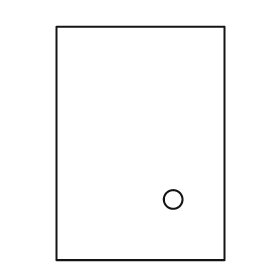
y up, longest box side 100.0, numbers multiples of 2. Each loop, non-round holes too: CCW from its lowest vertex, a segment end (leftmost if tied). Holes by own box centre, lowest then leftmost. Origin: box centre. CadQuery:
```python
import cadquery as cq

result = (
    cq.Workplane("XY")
    .moveTo(-36.0, -50.0)
    .lineTo(36.0, -50.0)
    .lineTo(36.0, 50.0)
    .lineTo(-36.0, 50.0)
    .close()
    .moveTo(14.0, -24.0)
    .circle(4.0)
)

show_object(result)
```